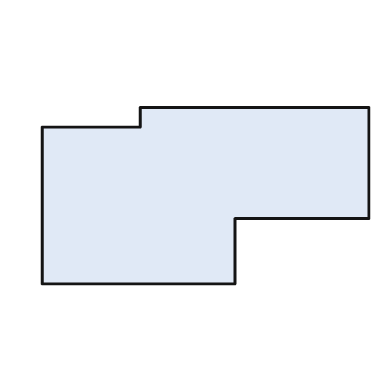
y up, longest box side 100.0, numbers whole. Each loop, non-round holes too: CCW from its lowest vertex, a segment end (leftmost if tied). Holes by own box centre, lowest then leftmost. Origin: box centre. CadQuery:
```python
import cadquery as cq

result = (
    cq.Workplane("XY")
    .moveTo(-50.0, -27.0)
    .lineTo(9.0, -27.0)
    .lineTo(9.0, -7.0)
    .lineTo(50.0, -7.0)
    .lineTo(50.0, 27.0)
    .lineTo(-20.0, 27.0)
    .lineTo(-20.0, 21.0)
    .lineTo(-50.0, 21.0)
    .close()
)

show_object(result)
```